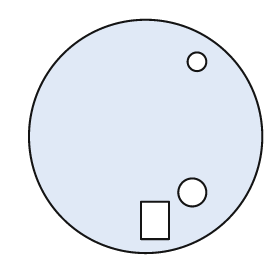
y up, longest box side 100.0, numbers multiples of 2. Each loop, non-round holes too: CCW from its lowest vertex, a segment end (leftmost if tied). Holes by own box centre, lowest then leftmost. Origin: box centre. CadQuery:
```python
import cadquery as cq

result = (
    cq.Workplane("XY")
    .moveTo(0.0, 0.0)
    .circle(50.0)
    .moveTo(-2.0, -44.0)
    .lineTo(10.0, -44.0)
    .lineTo(10.0, -28.0)
    .lineTo(-2.0, -28.0)
    .close()
    .moveTo(20.0, -24.0)
    .circle(6.0)
    .moveTo(22.0, 32.0)
    .circle(4.0)
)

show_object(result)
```